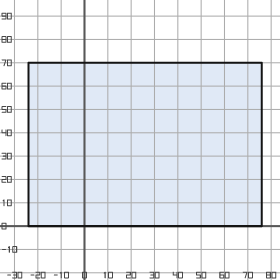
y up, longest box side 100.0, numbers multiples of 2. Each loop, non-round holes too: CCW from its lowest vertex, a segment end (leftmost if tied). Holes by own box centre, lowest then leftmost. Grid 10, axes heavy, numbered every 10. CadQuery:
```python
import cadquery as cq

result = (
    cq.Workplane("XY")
    .moveTo(-24.0, 0.0)
    .lineTo(76.0, 0.0)
    .lineTo(76.0, 70.0)
    .lineTo(-24.0, 70.0)
    .close()
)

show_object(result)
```